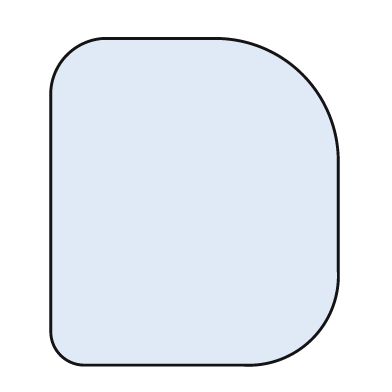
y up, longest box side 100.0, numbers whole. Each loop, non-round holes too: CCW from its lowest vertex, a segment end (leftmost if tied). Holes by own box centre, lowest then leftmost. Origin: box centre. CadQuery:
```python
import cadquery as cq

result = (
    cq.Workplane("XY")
    .moveTo(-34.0, -50.0)
    .lineTo(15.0, -50.0)
    .threePointArc((36.0, -42.0), (44.0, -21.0))
    .lineTo(44.0, 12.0)
    .threePointArc((33.0, 39.0), (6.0, 50.0))
    .lineTo(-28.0, 50.0)
    .threePointArc((-39.0, 45.0), (-44.0, 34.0))
    .lineTo(-44.0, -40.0)
    .threePointArc((-41.0, -47.0), (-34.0, -50.0))
    .close()
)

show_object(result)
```